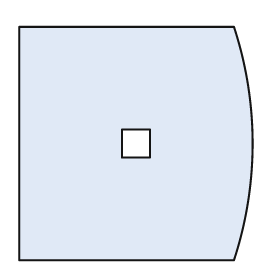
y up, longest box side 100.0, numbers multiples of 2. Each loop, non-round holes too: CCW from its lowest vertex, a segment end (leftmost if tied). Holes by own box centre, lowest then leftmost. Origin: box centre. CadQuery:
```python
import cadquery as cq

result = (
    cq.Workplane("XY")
    .moveTo(-50.0, -50.0)
    .lineTo(42.0, -50.0)
    .threePointArc((50.0, 0.0), (42.0, 50.0))
    .lineTo(-50.0, 50.0)
    .close()
    .moveTo(-6.0, -6.0)
    .lineTo(6.0, -6.0)
    .lineTo(6.0, 6.0)
    .lineTo(-6.0, 6.0)
    .close()
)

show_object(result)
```